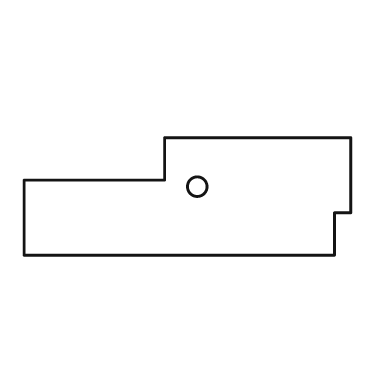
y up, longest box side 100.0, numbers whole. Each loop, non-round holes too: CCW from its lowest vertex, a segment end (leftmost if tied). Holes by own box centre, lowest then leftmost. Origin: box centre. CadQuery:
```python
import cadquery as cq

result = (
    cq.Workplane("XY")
    .moveTo(-50.0, -18.0)
    .lineTo(45.0, -18.0)
    .lineTo(45.0, -5.0)
    .lineTo(50.0, -5.0)
    .lineTo(50.0, 18.0)
    .lineTo(-7.0, 18.0)
    .lineTo(-7.0, 5.0)
    .lineTo(-50.0, 5.0)
    .close()
    .moveTo(3.0, 3.0)
    .circle(3.0)
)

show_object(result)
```